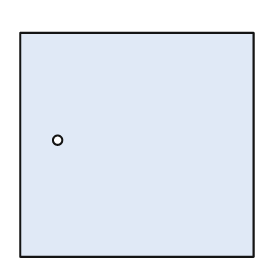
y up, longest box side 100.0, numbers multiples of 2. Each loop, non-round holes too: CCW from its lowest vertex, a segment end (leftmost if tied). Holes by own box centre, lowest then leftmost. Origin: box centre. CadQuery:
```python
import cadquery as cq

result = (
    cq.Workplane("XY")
    .moveTo(-50.0, -48.0)
    .lineTo(50.0, -48.0)
    .lineTo(50.0, 48.0)
    .lineTo(-50.0, 48.0)
    .close()
    .moveTo(-34.0, 2.0)
    .circle(2.0)
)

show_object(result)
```